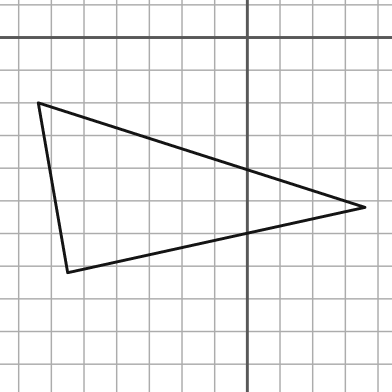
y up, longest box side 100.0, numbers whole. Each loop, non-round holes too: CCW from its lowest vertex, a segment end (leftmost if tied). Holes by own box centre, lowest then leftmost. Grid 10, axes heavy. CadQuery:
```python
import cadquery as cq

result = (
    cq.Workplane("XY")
    .moveTo(-55.0, -72.0)
    .lineTo(36.0, -52.0)
    .lineTo(-64.0, -20.0)
    .close()
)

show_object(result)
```